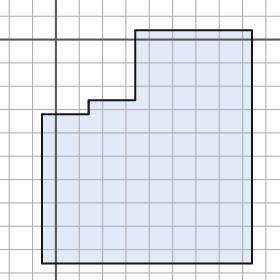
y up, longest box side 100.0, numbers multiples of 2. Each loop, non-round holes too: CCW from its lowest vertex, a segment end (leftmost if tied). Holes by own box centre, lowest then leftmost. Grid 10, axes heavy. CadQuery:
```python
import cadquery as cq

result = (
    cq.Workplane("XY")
    .moveTo(-6.0, -96.0)
    .lineTo(84.0, -96.0)
    .lineTo(84.0, 4.0)
    .lineTo(34.0, 4.0)
    .lineTo(34.0, -26.0)
    .lineTo(14.0, -26.0)
    .lineTo(14.0, -32.0)
    .lineTo(-6.0, -32.0)
    .close()
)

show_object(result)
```